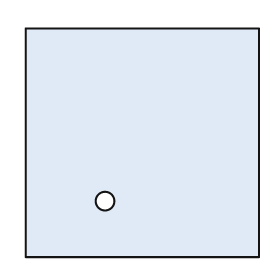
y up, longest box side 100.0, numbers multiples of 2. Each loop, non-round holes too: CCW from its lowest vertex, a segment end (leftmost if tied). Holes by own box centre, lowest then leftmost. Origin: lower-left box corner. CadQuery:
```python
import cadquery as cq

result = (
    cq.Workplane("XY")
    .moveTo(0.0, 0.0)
    .lineTo(100.0, 0.0)
    .lineTo(100.0, 98.0)
    .lineTo(0.0, 98.0)
    .close()
    .moveTo(34.0, 24.0)
    .circle(4.0)
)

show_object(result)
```